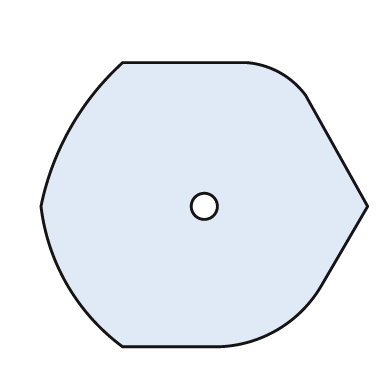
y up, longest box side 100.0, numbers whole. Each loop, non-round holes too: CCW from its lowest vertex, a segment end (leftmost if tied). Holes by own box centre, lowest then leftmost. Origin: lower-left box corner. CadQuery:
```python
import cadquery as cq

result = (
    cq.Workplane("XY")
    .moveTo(25.0, 0.0)
    .lineTo(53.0, 0.0)
    .threePointArc((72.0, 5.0), (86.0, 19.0))
    .lineTo(100.0, 43.0)
    .lineTo(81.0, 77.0)
    .threePointArc((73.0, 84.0), (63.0, 87.0))
    .lineTo(25.0, 87.0)
    .threePointArc((9.0, 67.0), (0.0, 43.0))
    .threePointArc((8.0, 19.0), (25.0, 0.0))
    .close()
    .moveTo(50.0, 43.0)
    .circle(4.0)
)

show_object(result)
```